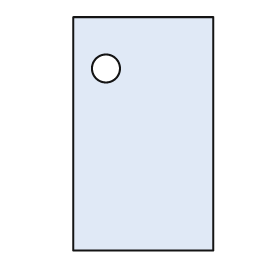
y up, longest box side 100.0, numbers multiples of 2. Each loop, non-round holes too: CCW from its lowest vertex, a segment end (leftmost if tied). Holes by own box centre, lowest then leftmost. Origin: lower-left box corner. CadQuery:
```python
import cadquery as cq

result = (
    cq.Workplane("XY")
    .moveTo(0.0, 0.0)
    .lineTo(60.0, 0.0)
    .lineTo(60.0, 100.0)
    .lineTo(0.0, 100.0)
    .close()
    .moveTo(14.0, 78.0)
    .circle(6.0)
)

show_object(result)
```